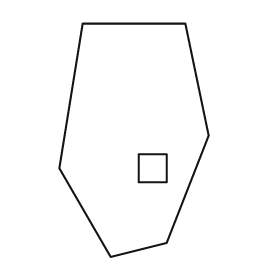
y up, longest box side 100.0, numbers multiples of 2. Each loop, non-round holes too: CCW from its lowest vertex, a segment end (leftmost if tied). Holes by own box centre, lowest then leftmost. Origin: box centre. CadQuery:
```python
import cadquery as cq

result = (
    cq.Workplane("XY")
    .moveTo(-10.0, -50.0)
    .lineTo(14.0, -44.0)
    .lineTo(32.0, 2.0)
    .lineTo(22.0, 50.0)
    .lineTo(-22.0, 50.0)
    .lineTo(-32.0, -12.0)
    .close()
    .moveTo(2.0, -18.0)
    .lineTo(14.0, -18.0)
    .lineTo(14.0, -6.0)
    .lineTo(2.0, -6.0)
    .close()
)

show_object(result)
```